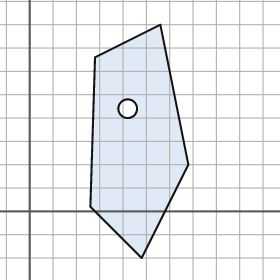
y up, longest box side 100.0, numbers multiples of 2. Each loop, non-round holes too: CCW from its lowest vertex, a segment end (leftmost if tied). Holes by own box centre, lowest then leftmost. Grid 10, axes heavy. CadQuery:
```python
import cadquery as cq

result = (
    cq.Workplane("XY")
    .moveTo(48.0, -20.0)
    .lineTo(68.0, 20.0)
    .lineTo(56.0, 80.0)
    .lineTo(28.0, 66.0)
    .lineTo(26.0, 2.0)
    .close()
    .moveTo(42.0, 44.0)
    .circle(4.0)
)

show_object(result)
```